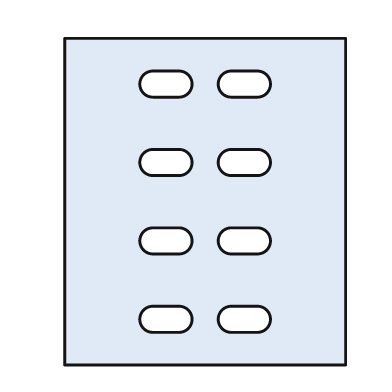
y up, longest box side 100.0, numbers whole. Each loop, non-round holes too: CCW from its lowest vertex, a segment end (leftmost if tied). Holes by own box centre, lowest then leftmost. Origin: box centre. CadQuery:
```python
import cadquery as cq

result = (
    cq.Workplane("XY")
    .moveTo(-43.0, -50.0)
    .lineTo(43.0, -50.0)
    .lineTo(43.0, 50.0)
    .lineTo(-43.0, 50.0)
    .close()
    .moveTo(-16.0, -40.0)
    .lineTo(-8.0, -40.0)
    .threePointArc((-4.0, -36.0), (-8.0, -32.0))
    .lineTo(-16.0, -32.0)
    .threePointArc((-20.0, -36.0), (-16.0, -40.0))
    .close()
    .moveTo(8.0, -40.0)
    .lineTo(16.0, -40.0)
    .threePointArc((20.0, -36.0), (16.0, -32.0))
    .lineTo(8.0, -32.0)
    .threePointArc((4.0, -36.0), (8.0, -40.0))
    .close()
    .moveTo(-16.0, -16.0)
    .lineTo(-8.0, -16.0)
    .threePointArc((-4.0, -12.0), (-8.0, -8.0))
    .lineTo(-16.0, -8.0)
    .threePointArc((-20.0, -12.0), (-16.0, -16.0))
    .close()
    .moveTo(8.0, -16.0)
    .lineTo(16.0, -16.0)
    .threePointArc((20.0, -12.0), (16.0, -8.0))
    .lineTo(8.0, -8.0)
    .threePointArc((4.0, -12.0), (8.0, -16.0))
    .close()
    .moveTo(-16.0, 8.0)
    .lineTo(-8.0, 8.0)
    .threePointArc((-4.0, 12.0), (-8.0, 16.0))
    .lineTo(-16.0, 16.0)
    .threePointArc((-20.0, 12.0), (-16.0, 8.0))
    .close()
    .moveTo(8.0, 8.0)
    .lineTo(16.0, 8.0)
    .threePointArc((20.0, 12.0), (16.0, 16.0))
    .lineTo(8.0, 16.0)
    .threePointArc((4.0, 12.0), (8.0, 8.0))
    .close()
    .moveTo(-16.0, 32.0)
    .lineTo(-8.0, 32.0)
    .threePointArc((-4.0, 36.0), (-8.0, 40.0))
    .lineTo(-16.0, 40.0)
    .threePointArc((-20.0, 36.0), (-16.0, 32.0))
    .close()
    .moveTo(8.0, 32.0)
    .lineTo(16.0, 32.0)
    .threePointArc((20.0, 36.0), (16.0, 40.0))
    .lineTo(8.0, 40.0)
    .threePointArc((4.0, 36.0), (8.0, 32.0))
    .close()
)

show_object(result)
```